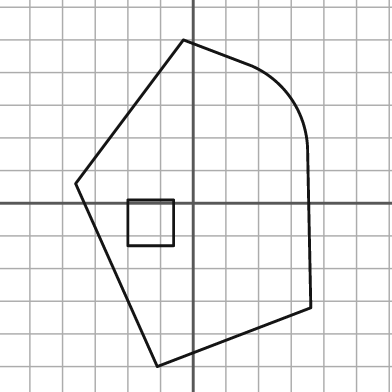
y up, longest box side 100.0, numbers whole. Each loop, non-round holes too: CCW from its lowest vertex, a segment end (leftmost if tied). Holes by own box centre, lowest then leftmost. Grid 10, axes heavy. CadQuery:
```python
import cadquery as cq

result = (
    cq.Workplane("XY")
    .moveTo(-11.0, -50.0)
    .lineTo(36.0, -32.0)
    .lineTo(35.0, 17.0)
    .threePointArc((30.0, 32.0), (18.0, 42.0))
    .lineTo(-3.0, 50.0)
    .lineTo(-36.0, 6.0)
    .close()
    .moveTo(-20.0, -13.0)
    .lineTo(-6.0, -13.0)
    .lineTo(-6.0, 1.0)
    .lineTo(-20.0, 1.0)
    .close()
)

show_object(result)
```